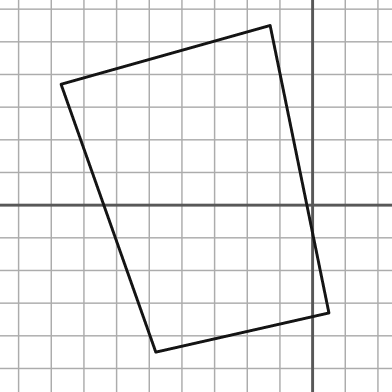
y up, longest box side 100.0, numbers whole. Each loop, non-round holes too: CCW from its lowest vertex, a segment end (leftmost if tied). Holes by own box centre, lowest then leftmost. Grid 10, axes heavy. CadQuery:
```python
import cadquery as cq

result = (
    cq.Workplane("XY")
    .moveTo(-48.0, -45.0)
    .lineTo(5.0, -33.0)
    .lineTo(-13.0, 55.0)
    .lineTo(-77.0, 37.0)
    .close()
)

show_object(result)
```